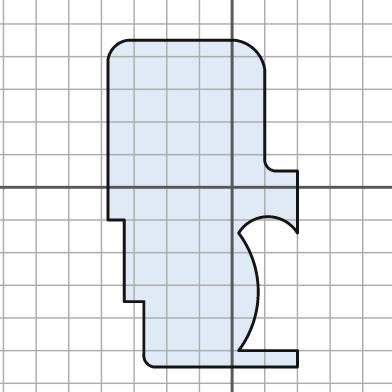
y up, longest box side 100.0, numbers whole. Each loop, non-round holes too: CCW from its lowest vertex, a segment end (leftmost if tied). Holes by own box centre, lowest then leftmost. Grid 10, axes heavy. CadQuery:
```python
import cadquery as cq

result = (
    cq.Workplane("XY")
    .moveTo(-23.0, -55.0)
    .lineTo(20.0, -55.0)
    .lineTo(20.0, -50.0)
    .lineTo(2.0, -50.0)
    .threePointArc((8.0, -32.0), (2.0, -14.0))
    .threePointArc((11.0, -9.0), (20.0, -14.0))
    .lineTo(20.0, 5.0)
    .lineTo(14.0, 5.0)
    .threePointArc((11.0, 6.0), (10.0, 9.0))
    .lineTo(10.0, 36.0)
    .threePointArc((7.0, 42.0), (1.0, 45.0))
    .lineTo(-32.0, 45.0)
    .threePointArc((-36.0, 43.0), (-38.0, 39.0))
    .lineTo(-38.0, -10.0)
    .lineTo(-33.0, -10.0)
    .lineTo(-33.0, -35.0)
    .lineTo(-27.0, -35.0)
    .lineTo(-27.0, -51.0)
    .threePointArc((-26.0, -54.0), (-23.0, -55.0))
    .close()
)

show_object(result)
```